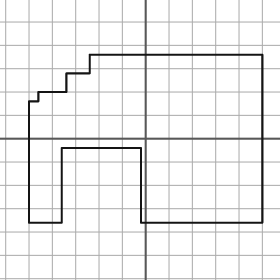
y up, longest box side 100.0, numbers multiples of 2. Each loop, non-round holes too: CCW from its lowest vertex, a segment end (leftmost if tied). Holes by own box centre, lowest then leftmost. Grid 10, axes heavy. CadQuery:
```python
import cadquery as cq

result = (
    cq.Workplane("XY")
    .moveTo(-50.0, -36.0)
    .lineTo(-36.0, -36.0)
    .lineTo(-36.0, -4.0)
    .lineTo(-2.0, -4.0)
    .lineTo(-2.0, -36.0)
    .lineTo(50.0, -36.0)
    .lineTo(50.0, 36.0)
    .lineTo(-24.0, 36.0)
    .lineTo(-24.0, 28.0)
    .lineTo(-34.0, 28.0)
    .lineTo(-34.0, 20.0)
    .lineTo(-46.0, 20.0)
    .lineTo(-46.0, 16.0)
    .lineTo(-50.0, 16.0)
    .close()
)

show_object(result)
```